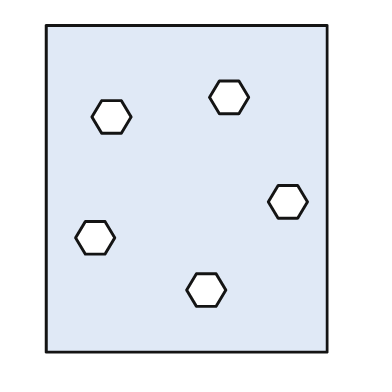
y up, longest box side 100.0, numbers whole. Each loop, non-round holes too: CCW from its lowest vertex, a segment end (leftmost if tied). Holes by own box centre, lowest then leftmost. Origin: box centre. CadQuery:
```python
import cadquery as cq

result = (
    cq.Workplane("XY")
    .moveTo(-43.0, -50.0)
    .lineTo(43.0, -50.0)
    .lineTo(43.0, 50.0)
    .lineTo(-43.0, 50.0)
    .close()
    .moveTo(3.0, -36.0)
    .lineTo(9.0, -36.0)
    .lineTo(12.0, -31.0)
    .lineTo(9.0, -26.0)
    .lineTo(3.0, -26.0)
    .lineTo(0.0, -31.0)
    .close()
    .moveTo(-31.0, -20.0)
    .lineTo(-25.0, -20.0)
    .lineTo(-22.0, -15.0)
    .lineTo(-25.0, -10.0)
    .lineTo(-31.0, -10.0)
    .lineTo(-34.0, -15.0)
    .close()
    .moveTo(28.0, -9.0)
    .lineTo(34.0, -9.0)
    .lineTo(37.0, -4.0)
    .lineTo(34.0, 1.0)
    .lineTo(28.0, 1.0)
    .lineTo(25.0, -4.0)
    .close()
    .moveTo(-26.0, 17.0)
    .lineTo(-20.0, 17.0)
    .lineTo(-17.0, 22.0)
    .lineTo(-20.0, 27.0)
    .lineTo(-26.0, 27.0)
    .lineTo(-29.0, 22.0)
    .close()
    .moveTo(10.0, 23.0)
    .lineTo(16.0, 23.0)
    .lineTo(19.0, 28.0)
    .lineTo(16.0, 33.0)
    .lineTo(10.0, 33.0)
    .lineTo(7.0, 28.0)
    .close()
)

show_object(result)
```